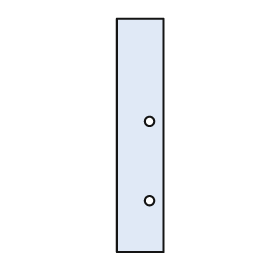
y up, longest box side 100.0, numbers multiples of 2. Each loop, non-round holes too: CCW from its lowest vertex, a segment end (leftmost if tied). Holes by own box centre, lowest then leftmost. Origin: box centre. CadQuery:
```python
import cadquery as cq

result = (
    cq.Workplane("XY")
    .moveTo(-10.0, -50.0)
    .lineTo(10.0, -50.0)
    .lineTo(10.0, 50.0)
    .lineTo(-10.0, 50.0)
    .close()
    .moveTo(4.0, -28.0)
    .circle(2.0)
    .moveTo(4.0, 6.0)
    .circle(2.0)
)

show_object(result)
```